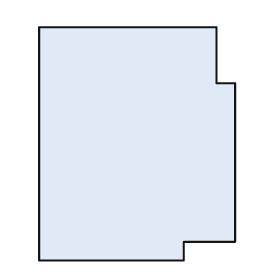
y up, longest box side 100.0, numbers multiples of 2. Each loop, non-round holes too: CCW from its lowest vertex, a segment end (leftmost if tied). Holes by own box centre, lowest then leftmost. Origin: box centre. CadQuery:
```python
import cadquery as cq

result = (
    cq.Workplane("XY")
    .moveTo(-42.0, -50.0)
    .lineTo(20.0, -50.0)
    .lineTo(20.0, -42.0)
    .lineTo(42.0, -42.0)
    .lineTo(42.0, 26.0)
    .lineTo(34.0, 26.0)
    .lineTo(34.0, 50.0)
    .lineTo(-42.0, 50.0)
    .close()
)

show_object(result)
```